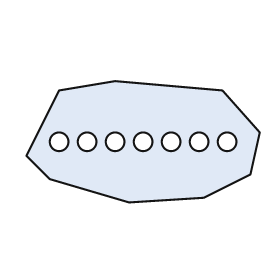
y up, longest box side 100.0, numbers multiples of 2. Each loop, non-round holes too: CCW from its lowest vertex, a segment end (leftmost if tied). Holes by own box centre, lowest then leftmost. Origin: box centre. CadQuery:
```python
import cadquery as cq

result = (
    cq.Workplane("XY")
    .moveTo(-6.0, -26.0)
    .lineTo(26.0, -24.0)
    .lineTo(46.0, -14.0)
    .lineTo(50.0, 4.0)
    .lineTo(34.0, 22.0)
    .lineTo(-12.0, 26.0)
    .lineTo(-36.0, 22.0)
    .lineTo(-50.0, -6.0)
    .lineTo(-40.0, -16.0)
    .close()
    .moveTo(-36.0, 0.0)
    .circle(4.0)
    .moveTo(-24.0, 0.0)
    .circle(4.0)
    .moveTo(-12.0, 0.0)
    .circle(4.0)
    .moveTo(0.0, 0.0)
    .circle(4.0)
    .moveTo(12.0, 0.0)
    .circle(4.0)
    .moveTo(24.0, 0.0)
    .circle(4.0)
    .moveTo(36.0, 0.0)
    .circle(4.0)
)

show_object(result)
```